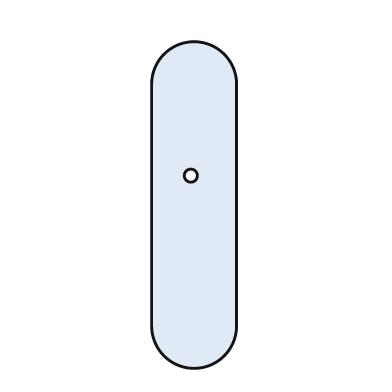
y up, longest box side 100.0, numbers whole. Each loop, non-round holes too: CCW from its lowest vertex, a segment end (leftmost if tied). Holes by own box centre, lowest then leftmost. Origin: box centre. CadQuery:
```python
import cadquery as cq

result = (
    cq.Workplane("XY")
    .moveTo(-13.0, -37.0)
    .threePointArc((0.0, -50.0), (13.0, -37.0))
    .lineTo(13.0, 37.0)
    .threePointArc((0.0, 50.0), (-13.0, 37.0))
    .close()
    .moveTo(-1.0, 9.0)
    .circle(2.0)
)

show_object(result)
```